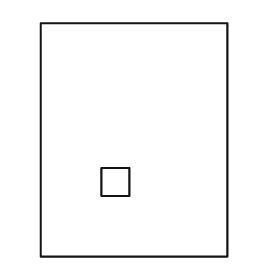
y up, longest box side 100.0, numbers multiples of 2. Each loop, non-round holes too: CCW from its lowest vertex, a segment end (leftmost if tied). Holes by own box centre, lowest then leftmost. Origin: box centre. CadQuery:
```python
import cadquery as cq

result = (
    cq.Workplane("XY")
    .moveTo(-40.0, -50.0)
    .lineTo(40.0, -50.0)
    .lineTo(40.0, 50.0)
    .lineTo(-40.0, 50.0)
    .close()
    .moveTo(-14.0, -24.0)
    .lineTo(-2.0, -24.0)
    .lineTo(-2.0, -12.0)
    .lineTo(-14.0, -12.0)
    .close()
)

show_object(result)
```